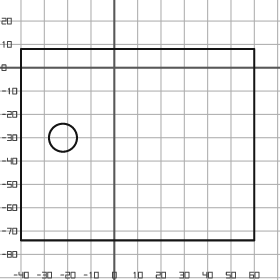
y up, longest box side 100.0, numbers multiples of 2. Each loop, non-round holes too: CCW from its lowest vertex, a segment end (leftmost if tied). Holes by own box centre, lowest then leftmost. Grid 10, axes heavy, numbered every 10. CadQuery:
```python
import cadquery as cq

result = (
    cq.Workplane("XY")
    .moveTo(-40.0, -74.0)
    .lineTo(60.0, -74.0)
    .lineTo(60.0, 8.0)
    .lineTo(-40.0, 8.0)
    .close()
    .moveTo(-22.0, -30.0)
    .circle(6.0)
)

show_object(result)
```